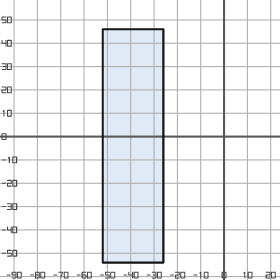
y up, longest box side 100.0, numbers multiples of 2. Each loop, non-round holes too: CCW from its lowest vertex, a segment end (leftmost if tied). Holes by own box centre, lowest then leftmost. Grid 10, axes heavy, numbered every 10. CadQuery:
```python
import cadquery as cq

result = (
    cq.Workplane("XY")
    .moveTo(-52.0, -54.0)
    .lineTo(-26.0, -54.0)
    .lineTo(-26.0, 46.0)
    .lineTo(-52.0, 46.0)
    .close()
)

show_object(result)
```